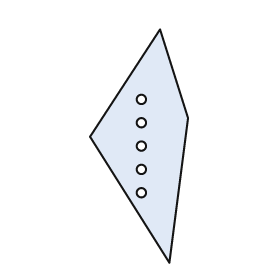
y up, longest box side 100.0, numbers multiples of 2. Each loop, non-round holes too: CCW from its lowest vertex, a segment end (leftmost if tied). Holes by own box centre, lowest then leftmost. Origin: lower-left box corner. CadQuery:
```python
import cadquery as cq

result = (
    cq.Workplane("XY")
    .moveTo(34.0, 0.0)
    .lineTo(42.0, 62.0)
    .lineTo(30.0, 100.0)
    .lineTo(0.0, 54.0)
    .close()
    .moveTo(22.0, 30.0)
    .circle(2.0)
    .moveTo(22.0, 40.0)
    .circle(2.0)
    .moveTo(22.0, 50.0)
    .circle(2.0)
    .moveTo(22.0, 60.0)
    .circle(2.0)
    .moveTo(22.0, 70.0)
    .circle(2.0)
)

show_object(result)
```